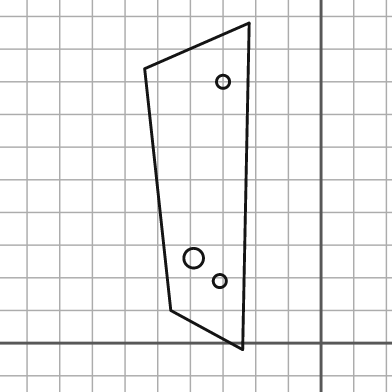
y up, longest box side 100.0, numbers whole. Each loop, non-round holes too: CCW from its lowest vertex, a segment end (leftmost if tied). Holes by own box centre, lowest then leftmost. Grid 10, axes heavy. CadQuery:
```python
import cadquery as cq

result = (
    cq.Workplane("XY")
    .moveTo(-24.0, -2.0)
    .lineTo(-22.0, 98.0)
    .lineTo(-54.0, 84.0)
    .lineTo(-46.0, 10.0)
    .close()
    .moveTo(-31.0, 19.0)
    .circle(2.0)
    .moveTo(-39.0, 26.0)
    .circle(3.0)
    .moveTo(-30.0, 80.0)
    .circle(2.0)
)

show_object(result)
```